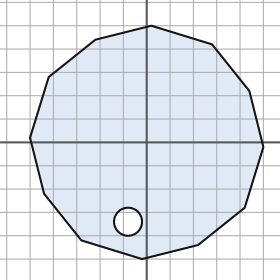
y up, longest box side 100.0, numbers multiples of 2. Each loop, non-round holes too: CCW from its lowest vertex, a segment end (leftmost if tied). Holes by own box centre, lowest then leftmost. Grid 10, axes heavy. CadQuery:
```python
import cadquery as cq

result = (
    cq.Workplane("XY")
    .moveTo(-2.0, -50.0)
    .lineTo(22.0, -44.0)
    .lineTo(42.0, -28.0)
    .lineTo(50.0, -2.0)
    .lineTo(44.0, 22.0)
    .lineTo(28.0, 42.0)
    .lineTo(2.0, 50.0)
    .lineTo(-22.0, 44.0)
    .lineTo(-42.0, 28.0)
    .lineTo(-50.0, 2.0)
    .lineTo(-44.0, -22.0)
    .lineTo(-28.0, -42.0)
    .close()
    .moveTo(-8.0, -34.0)
    .circle(6.0)
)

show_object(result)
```